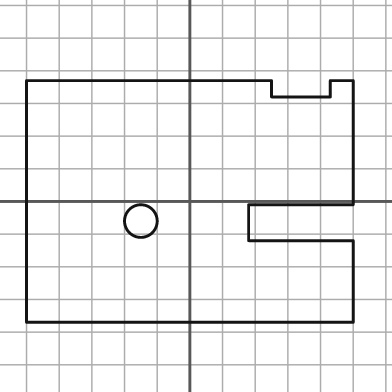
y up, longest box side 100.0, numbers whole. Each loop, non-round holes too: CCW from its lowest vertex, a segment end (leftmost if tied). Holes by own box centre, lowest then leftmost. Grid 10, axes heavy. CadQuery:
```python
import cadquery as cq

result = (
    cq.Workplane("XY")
    .moveTo(-50.0, -37.0)
    .lineTo(50.0, -37.0)
    .lineTo(50.0, -12.0)
    .lineTo(18.0, -12.0)
    .lineTo(18.0, -1.0)
    .lineTo(50.0, -1.0)
    .lineTo(50.0, 37.0)
    .lineTo(43.0, 37.0)
    .lineTo(43.0, 32.0)
    .lineTo(25.0, 32.0)
    .lineTo(25.0, 37.0)
    .lineTo(-50.0, 37.0)
    .close()
    .moveTo(-15.0, -6.0)
    .circle(5.0)
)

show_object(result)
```